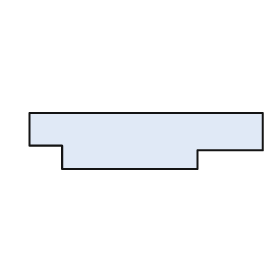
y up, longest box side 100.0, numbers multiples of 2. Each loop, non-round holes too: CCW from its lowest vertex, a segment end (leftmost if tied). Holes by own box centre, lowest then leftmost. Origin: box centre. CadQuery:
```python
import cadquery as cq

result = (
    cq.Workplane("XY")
    .moveTo(-36.0, -12.0)
    .lineTo(22.0, -12.0)
    .lineTo(22.0, -4.0)
    .lineTo(50.0, -4.0)
    .lineTo(50.0, 12.0)
    .lineTo(-50.0, 12.0)
    .lineTo(-50.0, -2.0)
    .lineTo(-36.0, -2.0)
    .close()
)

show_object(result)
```